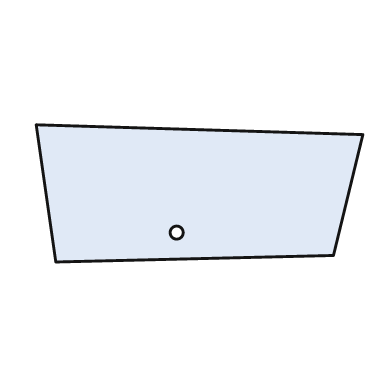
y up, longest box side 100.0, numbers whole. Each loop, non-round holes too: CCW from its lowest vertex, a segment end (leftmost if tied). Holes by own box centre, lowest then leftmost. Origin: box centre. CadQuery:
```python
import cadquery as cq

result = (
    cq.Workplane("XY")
    .moveTo(-44.0, -21.0)
    .lineTo(41.0, -19.0)
    .lineTo(50.0, 18.0)
    .lineTo(-50.0, 21.0)
    .close()
    .moveTo(-7.0, -12.0)
    .circle(2.0)
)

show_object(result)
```